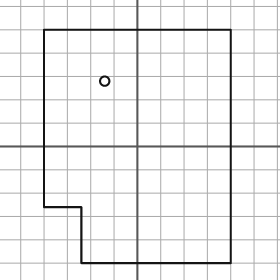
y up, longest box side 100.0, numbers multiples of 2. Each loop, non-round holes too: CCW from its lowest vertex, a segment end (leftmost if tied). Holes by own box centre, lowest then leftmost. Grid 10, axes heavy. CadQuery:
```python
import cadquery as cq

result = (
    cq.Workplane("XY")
    .moveTo(-24.0, -50.0)
    .lineTo(40.0, -50.0)
    .lineTo(40.0, 50.0)
    .lineTo(-40.0, 50.0)
    .lineTo(-40.0, -26.0)
    .lineTo(-24.0, -26.0)
    .close()
    .moveTo(-14.0, 28.0)
    .circle(2.0)
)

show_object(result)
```